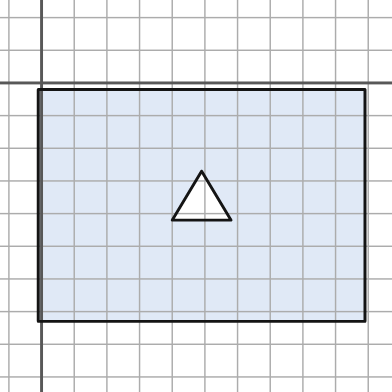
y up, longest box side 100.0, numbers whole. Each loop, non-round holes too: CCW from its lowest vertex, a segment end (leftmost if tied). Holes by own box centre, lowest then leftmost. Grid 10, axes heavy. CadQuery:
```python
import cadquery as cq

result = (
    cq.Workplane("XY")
    .moveTo(-1.0, -73.0)
    .lineTo(99.0, -73.0)
    .lineTo(99.0, -2.0)
    .lineTo(-1.0, -2.0)
    .close()
    .moveTo(40.0, -42.0)
    .lineTo(58.0, -42.0)
    .lineTo(49.0, -27.0)
    .close()
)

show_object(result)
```